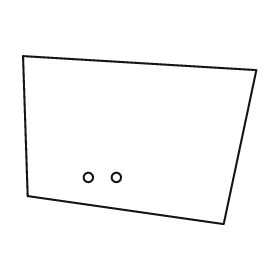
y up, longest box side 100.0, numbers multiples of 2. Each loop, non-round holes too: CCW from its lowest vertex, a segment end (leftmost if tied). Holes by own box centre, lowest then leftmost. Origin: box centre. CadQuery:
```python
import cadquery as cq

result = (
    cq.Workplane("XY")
    .moveTo(36.0, -36.0)
    .lineTo(50.0, 30.0)
    .lineTo(-50.0, 36.0)
    .lineTo(-48.0, -24.0)
    .close()
    .moveTo(-22.0, -16.0)
    .circle(2.0)
    .moveTo(-10.0, -16.0)
    .circle(2.0)
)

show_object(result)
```